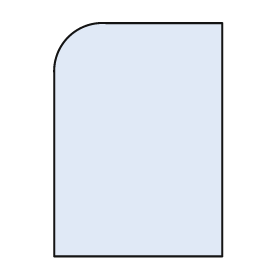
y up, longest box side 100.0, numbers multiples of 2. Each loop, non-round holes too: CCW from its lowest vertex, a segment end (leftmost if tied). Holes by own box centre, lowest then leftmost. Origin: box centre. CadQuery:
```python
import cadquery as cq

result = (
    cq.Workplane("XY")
    .moveTo(-36.0, -50.0)
    .lineTo(36.0, -50.0)
    .lineTo(36.0, 50.0)
    .lineTo(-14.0, 50.0)
    .threePointArc((-30.0, 44.0), (-36.0, 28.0))
    .close()
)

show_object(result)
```